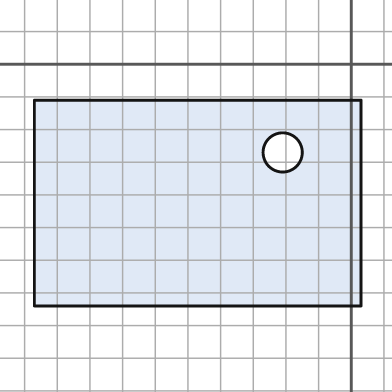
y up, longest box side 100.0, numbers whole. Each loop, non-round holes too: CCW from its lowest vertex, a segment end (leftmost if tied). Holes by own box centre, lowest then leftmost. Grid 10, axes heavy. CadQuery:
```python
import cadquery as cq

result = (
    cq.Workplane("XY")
    .moveTo(-97.0, -74.0)
    .lineTo(3.0, -74.0)
    .lineTo(3.0, -11.0)
    .lineTo(-97.0, -11.0)
    .close()
    .moveTo(-21.0, -27.0)
    .circle(6.0)
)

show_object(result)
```